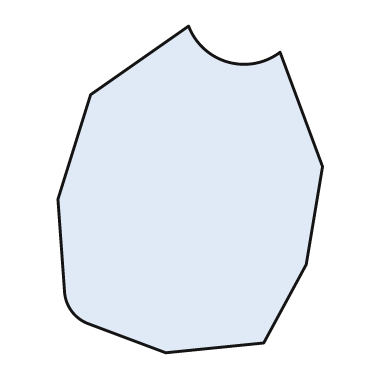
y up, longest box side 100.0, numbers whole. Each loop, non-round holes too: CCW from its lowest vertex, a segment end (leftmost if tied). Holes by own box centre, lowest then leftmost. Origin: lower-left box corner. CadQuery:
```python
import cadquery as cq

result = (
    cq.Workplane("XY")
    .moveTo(33.0, 0.0)
    .lineTo(63.0, 3.0)
    .lineTo(76.0, 27.0)
    .lineTo(81.0, 57.0)
    .lineTo(68.0, 92.0)
    .threePointArc((52.0, 89.0), (40.0, 100.0))
    .lineTo(10.0, 79.0)
    .lineTo(0.0, 47.0)
    .lineTo(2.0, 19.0)
    .threePointArc((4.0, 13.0), (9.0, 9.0))
    .close()
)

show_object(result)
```